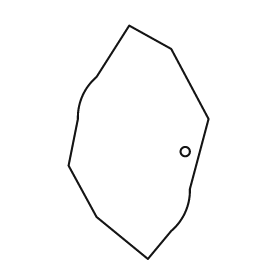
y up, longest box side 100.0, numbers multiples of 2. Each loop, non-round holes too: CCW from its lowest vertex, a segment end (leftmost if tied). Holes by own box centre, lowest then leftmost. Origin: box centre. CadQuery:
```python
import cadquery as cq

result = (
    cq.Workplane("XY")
    .moveTo(4.0, -50.0)
    .lineTo(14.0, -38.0)
    .threePointArc((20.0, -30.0), (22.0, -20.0))
    .lineTo(30.0, 10.0)
    .lineTo(14.0, 40.0)
    .lineTo(-4.0, 50.0)
    .lineTo(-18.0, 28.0)
    .threePointArc((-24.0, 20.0), (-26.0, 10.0))
    .lineTo(-30.0, -10.0)
    .lineTo(-18.0, -32.0)
    .close()
    .moveTo(20.0, -4.0)
    .circle(2.0)
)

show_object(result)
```